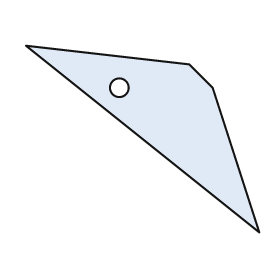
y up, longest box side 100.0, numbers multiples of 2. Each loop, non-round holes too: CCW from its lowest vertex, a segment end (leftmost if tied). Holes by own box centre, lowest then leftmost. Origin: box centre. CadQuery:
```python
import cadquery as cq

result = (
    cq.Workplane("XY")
    .moveTo(50.0, -40.0)
    .lineTo(30.0, 22.0)
    .lineTo(20.0, 32.0)
    .lineTo(-50.0, 40.0)
    .close()
    .moveTo(-10.0, 22.0)
    .circle(4.0)
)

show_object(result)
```